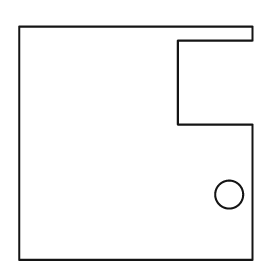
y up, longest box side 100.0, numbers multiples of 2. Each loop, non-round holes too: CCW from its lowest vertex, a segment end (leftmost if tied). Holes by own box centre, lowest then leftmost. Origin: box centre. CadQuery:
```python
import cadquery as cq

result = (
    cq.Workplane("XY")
    .moveTo(-50.0, -50.0)
    .lineTo(50.0, -50.0)
    .lineTo(50.0, 8.0)
    .lineTo(18.0, 8.0)
    .lineTo(18.0, 44.0)
    .lineTo(50.0, 44.0)
    .lineTo(50.0, 50.0)
    .lineTo(-50.0, 50.0)
    .close()
    .moveTo(40.0, -22.0)
    .circle(6.0)
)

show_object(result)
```